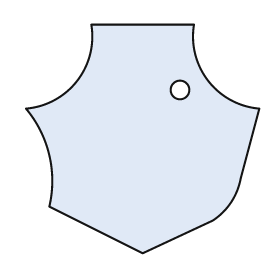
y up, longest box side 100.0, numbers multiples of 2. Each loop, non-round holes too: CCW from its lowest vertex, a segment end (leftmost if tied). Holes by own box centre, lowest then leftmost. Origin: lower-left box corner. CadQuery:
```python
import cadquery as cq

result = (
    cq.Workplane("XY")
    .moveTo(50.0, 0.0)
    .lineTo(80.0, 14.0)
    .threePointArc((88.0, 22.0), (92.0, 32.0))
    .lineTo(100.0, 62.0)
    .threePointArc((78.0, 74.0), (72.0, 98.0))
    .lineTo(28.0, 98.0)
    .threePointArc((22.0, 74.0), (0.0, 62.0))
    .threePointArc((10.0, 42.0), (10.0, 20.0))
    .close()
    .moveTo(66.0, 70.0)
    .circle(4.0)
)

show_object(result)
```